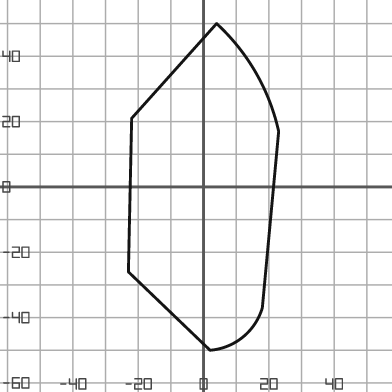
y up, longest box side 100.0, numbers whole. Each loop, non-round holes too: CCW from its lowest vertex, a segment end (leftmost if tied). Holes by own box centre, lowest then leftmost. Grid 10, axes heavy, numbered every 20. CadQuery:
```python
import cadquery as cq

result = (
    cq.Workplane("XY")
    .moveTo(2.0, -50.0)
    .threePointArc((12.0, -46.0), (18.0, -37.0))
    .lineTo(23.0, 17.0)
    .threePointArc((16.0, 35.0), (4.0, 50.0))
    .lineTo(-22.0, 21.0)
    .lineTo(-23.0, -26.0)
    .close()
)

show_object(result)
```